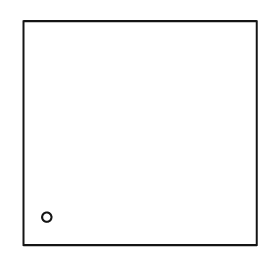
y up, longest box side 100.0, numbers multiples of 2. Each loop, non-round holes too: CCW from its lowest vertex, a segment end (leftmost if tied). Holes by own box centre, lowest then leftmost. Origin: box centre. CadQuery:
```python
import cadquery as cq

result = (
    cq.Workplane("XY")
    .moveTo(-50.0, -48.0)
    .lineTo(50.0, -48.0)
    .lineTo(50.0, 48.0)
    .lineTo(-50.0, 48.0)
    .close()
    .moveTo(-40.0, -36.0)
    .circle(2.0)
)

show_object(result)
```